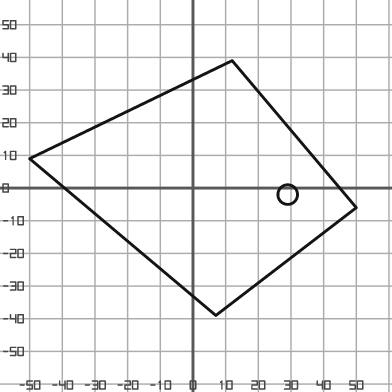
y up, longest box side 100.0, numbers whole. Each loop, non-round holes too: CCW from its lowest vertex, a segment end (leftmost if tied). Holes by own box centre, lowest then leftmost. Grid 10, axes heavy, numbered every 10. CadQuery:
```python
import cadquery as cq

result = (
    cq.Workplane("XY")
    .moveTo(7.0, -39.0)
    .lineTo(50.0, -6.0)
    .lineTo(12.0, 39.0)
    .lineTo(-50.0, 9.0)
    .close()
    .moveTo(29.0, -2.0)
    .circle(3.0)
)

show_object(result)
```